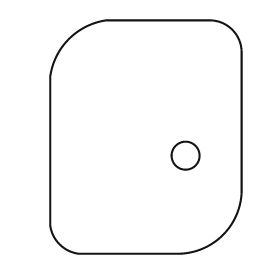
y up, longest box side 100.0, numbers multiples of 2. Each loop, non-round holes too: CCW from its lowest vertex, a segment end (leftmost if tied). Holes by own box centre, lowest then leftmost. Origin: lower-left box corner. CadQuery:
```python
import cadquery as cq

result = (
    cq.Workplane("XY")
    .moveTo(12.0, 0.0)
    .lineTo(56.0, 0.0)
    .threePointArc((74.0, 8.0), (82.0, 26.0))
    .lineTo(82.0, 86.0)
    .threePointArc((78.0, 96.0), (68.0, 100.0))
    .lineTo(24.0, 100.0)
    .threePointArc((8.0, 92.0), (0.0, 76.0))
    .lineTo(0.0, 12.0)
    .threePointArc((4.0, 4.0), (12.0, 0.0))
    .close()
    .moveTo(58.0, 42.0)
    .circle(6.0)
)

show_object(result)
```